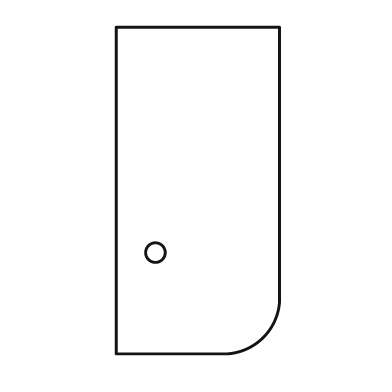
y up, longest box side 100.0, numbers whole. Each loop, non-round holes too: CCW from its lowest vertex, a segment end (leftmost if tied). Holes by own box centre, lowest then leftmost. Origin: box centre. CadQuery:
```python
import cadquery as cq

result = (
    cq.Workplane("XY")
    .moveTo(-25.0, -50.0)
    .lineTo(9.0, -50.0)
    .threePointArc((20.0, -45.0), (25.0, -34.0))
    .lineTo(25.0, 50.0)
    .lineTo(-25.0, 50.0)
    .close()
    .moveTo(-13.0, -19.0)
    .circle(3.0)
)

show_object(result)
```